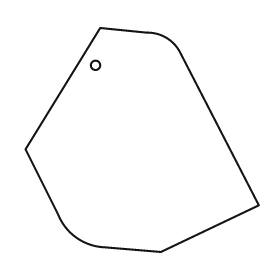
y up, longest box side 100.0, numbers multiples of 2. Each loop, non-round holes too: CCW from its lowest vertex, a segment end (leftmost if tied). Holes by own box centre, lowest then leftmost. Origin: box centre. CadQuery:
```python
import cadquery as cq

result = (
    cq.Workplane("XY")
    .moveTo(8.0, -48.0)
    .lineTo(50.0, -28.0)
    .lineTo(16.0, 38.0)
    .threePointArc((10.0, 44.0), (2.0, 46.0))
    .lineTo(-18.0, 48.0)
    .lineTo(-50.0, -4.0)
    .lineTo(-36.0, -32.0)
    .threePointArc((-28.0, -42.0), (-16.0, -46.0))
    .close()
    .moveTo(-20.0, 32.0)
    .circle(2.0)
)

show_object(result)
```